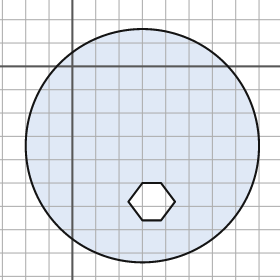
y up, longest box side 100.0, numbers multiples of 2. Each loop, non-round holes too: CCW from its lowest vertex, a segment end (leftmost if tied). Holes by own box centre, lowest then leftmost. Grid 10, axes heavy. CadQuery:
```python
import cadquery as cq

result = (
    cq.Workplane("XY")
    .moveTo(30.0, -34.0)
    .circle(50.0)
    .moveTo(30.0, -66.0)
    .lineTo(38.0, -66.0)
    .lineTo(44.0, -58.0)
    .lineTo(38.0, -50.0)
    .lineTo(30.0, -50.0)
    .lineTo(24.0, -58.0)
    .close()
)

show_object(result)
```